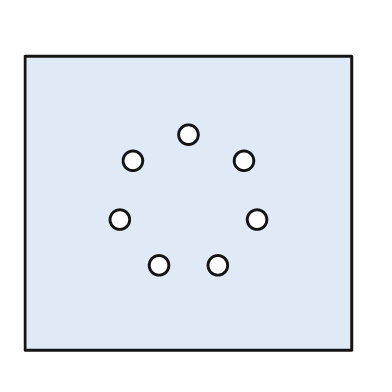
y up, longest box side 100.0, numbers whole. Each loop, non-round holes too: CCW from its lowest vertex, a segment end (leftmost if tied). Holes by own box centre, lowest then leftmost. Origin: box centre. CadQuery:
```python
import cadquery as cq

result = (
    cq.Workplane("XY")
    .moveTo(-50.0, -45.0)
    .lineTo(50.0, -45.0)
    .lineTo(50.0, 45.0)
    .lineTo(-50.0, 45.0)
    .close()
    .moveTo(-9.0, -19.0)
    .circle(3.0)
    .moveTo(9.0, -19.0)
    .circle(3.0)
    .moveTo(-21.0, -5.0)
    .circle(3.0)
    .moveTo(21.0, -5.0)
    .circle(3.0)
    .moveTo(-17.0, 13.0)
    .circle(3.0)
    .moveTo(17.0, 13.0)
    .circle(3.0)
    .moveTo(0.0, 21.0)
    .circle(3.0)
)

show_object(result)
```